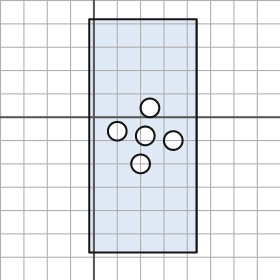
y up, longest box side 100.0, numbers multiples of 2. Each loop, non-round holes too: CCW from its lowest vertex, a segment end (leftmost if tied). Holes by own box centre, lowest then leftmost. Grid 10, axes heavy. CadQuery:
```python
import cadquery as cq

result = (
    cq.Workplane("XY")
    .moveTo(-2.0, -58.0)
    .lineTo(44.0, -58.0)
    .lineTo(44.0, 42.0)
    .lineTo(-2.0, 42.0)
    .close()
    .moveTo(20.0, -20.0)
    .circle(4.0)
    .moveTo(34.0, -10.0)
    .circle(4.0)
    .moveTo(22.0, -8.0)
    .circle(4.0)
    .moveTo(10.0, -6.0)
    .circle(4.0)
    .moveTo(24.0, 4.0)
    .circle(4.0)
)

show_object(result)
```